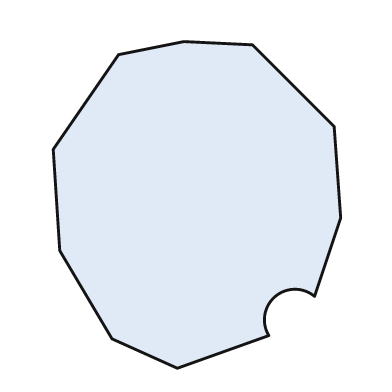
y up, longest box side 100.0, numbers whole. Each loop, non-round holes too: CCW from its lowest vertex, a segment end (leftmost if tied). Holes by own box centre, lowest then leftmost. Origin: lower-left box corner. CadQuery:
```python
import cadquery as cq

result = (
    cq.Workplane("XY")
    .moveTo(38.0, 0.0)
    .lineTo(66.0, 10.0)
    .threePointArc((68.0, 22.0), (80.0, 22.0))
    .lineTo(88.0, 46.0)
    .lineTo(86.0, 74.0)
    .lineTo(61.0, 99.0)
    .lineTo(40.0, 100.0)
    .lineTo(20.0, 96.0)
    .lineTo(0.0, 67.0)
    .lineTo(2.0, 36.0)
    .lineTo(18.0, 9.0)
    .close()
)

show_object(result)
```